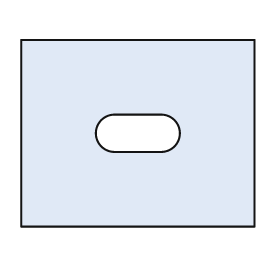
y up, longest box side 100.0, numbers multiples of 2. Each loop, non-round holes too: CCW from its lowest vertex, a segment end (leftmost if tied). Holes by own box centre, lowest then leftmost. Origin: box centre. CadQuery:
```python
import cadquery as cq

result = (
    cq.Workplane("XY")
    .moveTo(-50.0, -40.0)
    .lineTo(50.0, -40.0)
    .lineTo(50.0, 40.0)
    .lineTo(-50.0, 40.0)
    .close()
    .moveTo(-10.0, -8.0)
    .lineTo(10.0, -8.0)
    .threePointArc((18.0, 0.0), (10.0, 8.0))
    .lineTo(-10.0, 8.0)
    .threePointArc((-18.0, 0.0), (-10.0, -8.0))
    .close()
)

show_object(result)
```